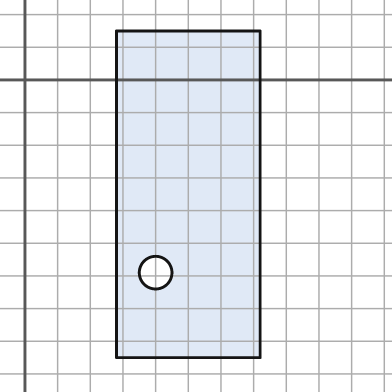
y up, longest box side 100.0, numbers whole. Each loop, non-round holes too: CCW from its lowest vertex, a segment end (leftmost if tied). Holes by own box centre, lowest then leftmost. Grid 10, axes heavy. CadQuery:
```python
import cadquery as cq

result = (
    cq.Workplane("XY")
    .moveTo(28.0, -85.0)
    .lineTo(72.0, -85.0)
    .lineTo(72.0, 15.0)
    .lineTo(28.0, 15.0)
    .close()
    .moveTo(40.0, -59.0)
    .circle(5.0)
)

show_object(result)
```